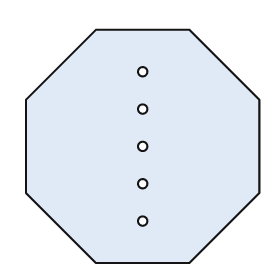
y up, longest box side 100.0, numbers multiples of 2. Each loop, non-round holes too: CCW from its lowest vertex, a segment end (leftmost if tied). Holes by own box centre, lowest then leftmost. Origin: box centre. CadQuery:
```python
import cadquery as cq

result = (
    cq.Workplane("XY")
    .moveTo(-20.0, -50.0)
    .lineTo(20.0, -50.0)
    .lineTo(50.0, -20.0)
    .lineTo(50.0, 20.0)
    .lineTo(20.0, 50.0)
    .lineTo(-20.0, 50.0)
    .lineTo(-50.0, 20.0)
    .lineTo(-50.0, -20.0)
    .close()
    .moveTo(0.0, -32.0)
    .circle(2.0)
    .moveTo(0.0, -16.0)
    .circle(2.0)
    .moveTo(0.0, 0.0)
    .circle(2.0)
    .moveTo(0.0, 16.0)
    .circle(2.0)
    .moveTo(0.0, 32.0)
    .circle(2.0)
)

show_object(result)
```